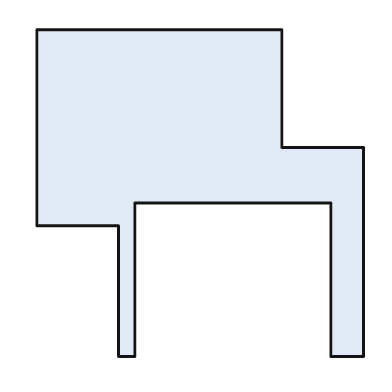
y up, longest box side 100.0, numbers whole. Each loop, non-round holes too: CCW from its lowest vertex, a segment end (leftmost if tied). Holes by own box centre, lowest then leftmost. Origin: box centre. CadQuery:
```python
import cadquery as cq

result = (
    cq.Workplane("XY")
    .moveTo(-25.0, -50.0)
    .lineTo(-20.0, -50.0)
    .lineTo(-20.0, -3.0)
    .lineTo(40.0, -3.0)
    .lineTo(40.0, -50.0)
    .lineTo(50.0, -50.0)
    .lineTo(50.0, 14.0)
    .lineTo(25.0, 14.0)
    .lineTo(25.0, 50.0)
    .lineTo(-50.0, 50.0)
    .lineTo(-50.0, -10.0)
    .lineTo(-25.0, -10.0)
    .close()
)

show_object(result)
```